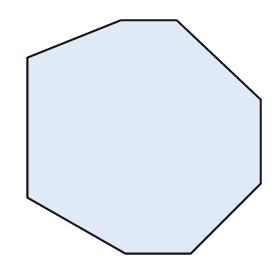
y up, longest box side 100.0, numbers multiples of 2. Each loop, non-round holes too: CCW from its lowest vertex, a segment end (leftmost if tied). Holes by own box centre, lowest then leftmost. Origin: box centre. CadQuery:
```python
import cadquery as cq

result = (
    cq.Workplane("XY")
    .moveTo(-8.0, -50.0)
    .lineTo(20.0, -50.0)
    .lineTo(50.0, -20.0)
    .lineTo(50.0, 16.0)
    .lineTo(14.0, 50.0)
    .lineTo(-10.0, 50.0)
    .lineTo(-50.0, 34.0)
    .lineTo(-50.0, -26.0)
    .close()
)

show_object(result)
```